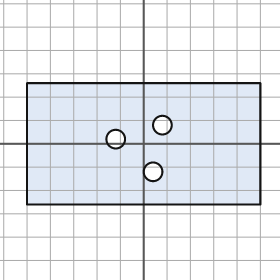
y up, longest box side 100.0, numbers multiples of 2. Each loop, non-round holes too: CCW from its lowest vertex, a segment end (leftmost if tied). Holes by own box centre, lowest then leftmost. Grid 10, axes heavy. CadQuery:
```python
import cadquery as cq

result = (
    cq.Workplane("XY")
    .moveTo(-50.0, -26.0)
    .lineTo(50.0, -26.0)
    .lineTo(50.0, 26.0)
    .lineTo(-50.0, 26.0)
    .close()
    .moveTo(4.0, -12.0)
    .circle(4.0)
    .moveTo(-12.0, 2.0)
    .circle(4.0)
    .moveTo(8.0, 8.0)
    .circle(4.0)
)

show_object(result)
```